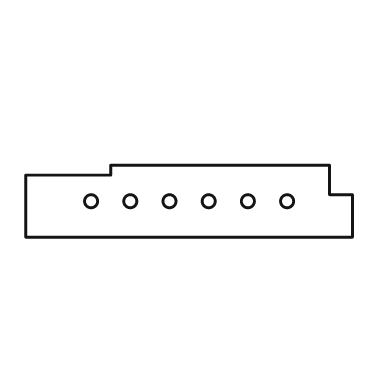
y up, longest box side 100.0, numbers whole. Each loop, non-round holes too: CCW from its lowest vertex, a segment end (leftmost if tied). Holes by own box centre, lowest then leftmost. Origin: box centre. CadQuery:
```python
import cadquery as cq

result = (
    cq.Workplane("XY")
    .moveTo(-50.0, -11.0)
    .lineTo(50.0, -11.0)
    .lineTo(50.0, 2.0)
    .lineTo(43.0, 2.0)
    .lineTo(43.0, 11.0)
    .lineTo(-24.0, 11.0)
    .lineTo(-24.0, 8.0)
    .lineTo(-50.0, 8.0)
    .close()
    .moveTo(-30.0, 0.0)
    .circle(2.0)
    .moveTo(-18.0, 0.0)
    .circle(2.0)
    .moveTo(-6.0, 0.0)
    .circle(2.0)
    .moveTo(6.0, 0.0)
    .circle(2.0)
    .moveTo(18.0, 0.0)
    .circle(2.0)
    .moveTo(30.0, 0.0)
    .circle(2.0)
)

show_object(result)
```